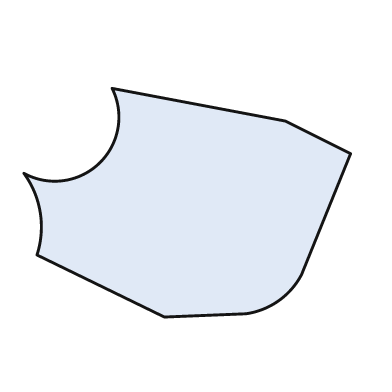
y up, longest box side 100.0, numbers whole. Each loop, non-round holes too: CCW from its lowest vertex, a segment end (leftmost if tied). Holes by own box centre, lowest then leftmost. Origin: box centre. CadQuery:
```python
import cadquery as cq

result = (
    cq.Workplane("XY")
    .moveTo(-7.0, -35.0)
    .lineTo(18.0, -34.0)
    .threePointArc((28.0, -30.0), (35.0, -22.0))
    .lineTo(50.0, 15.0)
    .lineTo(30.0, 25.0)
    .lineTo(-23.0, 35.0)
    .threePointArc((-27.0, 12.0), (-50.0, 9.0))
    .threePointArc((-45.0, -3.0), (-46.0, -16.0))
    .close()
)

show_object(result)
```